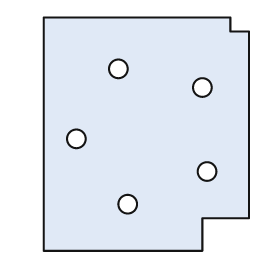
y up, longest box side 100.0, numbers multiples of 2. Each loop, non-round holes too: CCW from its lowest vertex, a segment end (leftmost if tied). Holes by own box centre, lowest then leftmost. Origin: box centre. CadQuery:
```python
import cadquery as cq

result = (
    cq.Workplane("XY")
    .moveTo(-44.0, -50.0)
    .lineTo(24.0, -50.0)
    .lineTo(24.0, -36.0)
    .lineTo(44.0, -36.0)
    .lineTo(44.0, 44.0)
    .lineTo(36.0, 44.0)
    .lineTo(36.0, 50.0)
    .lineTo(-44.0, 50.0)
    .close()
    .moveTo(-8.0, -30.0)
    .circle(4.0)
    .moveTo(26.0, -16.0)
    .circle(4.0)
    .moveTo(-30.0, -2.0)
    .circle(4.0)
    .moveTo(24.0, 20.0)
    .circle(4.0)
    .moveTo(-12.0, 28.0)
    .circle(4.0)
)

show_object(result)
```